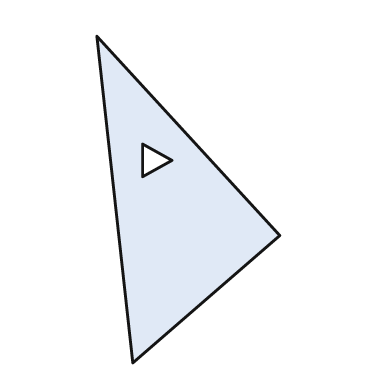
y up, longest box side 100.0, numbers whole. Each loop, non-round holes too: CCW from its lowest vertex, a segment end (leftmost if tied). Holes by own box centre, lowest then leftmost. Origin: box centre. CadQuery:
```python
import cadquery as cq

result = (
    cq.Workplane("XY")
    .moveTo(-17.0, -50.0)
    .lineTo(28.0, -11.0)
    .lineTo(-28.0, 50.0)
    .close()
    .moveTo(-14.0, 7.0)
    .lineTo(-5.0, 12.0)
    .lineTo(-14.0, 17.0)
    .close()
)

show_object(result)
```